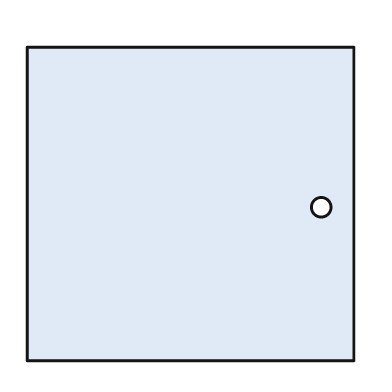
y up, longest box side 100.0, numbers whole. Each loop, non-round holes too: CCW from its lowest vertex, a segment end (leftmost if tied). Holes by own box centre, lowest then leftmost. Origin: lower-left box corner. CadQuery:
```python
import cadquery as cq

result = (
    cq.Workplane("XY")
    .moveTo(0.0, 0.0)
    .lineTo(100.0, 0.0)
    .lineTo(100.0, 96.0)
    .lineTo(0.0, 96.0)
    .close()
    .moveTo(90.0, 47.0)
    .circle(3.0)
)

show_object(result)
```